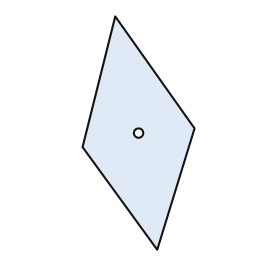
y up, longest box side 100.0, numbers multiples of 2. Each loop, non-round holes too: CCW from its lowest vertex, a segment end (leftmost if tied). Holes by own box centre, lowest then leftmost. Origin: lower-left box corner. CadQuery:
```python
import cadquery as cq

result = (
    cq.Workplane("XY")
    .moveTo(32.0, 0.0)
    .lineTo(48.0, 52.0)
    .lineTo(14.0, 100.0)
    .lineTo(0.0, 44.0)
    .close()
    .moveTo(24.0, 50.0)
    .circle(2.0)
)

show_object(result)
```